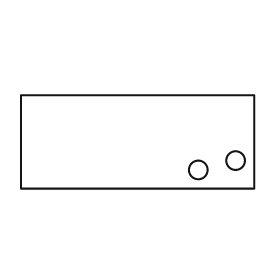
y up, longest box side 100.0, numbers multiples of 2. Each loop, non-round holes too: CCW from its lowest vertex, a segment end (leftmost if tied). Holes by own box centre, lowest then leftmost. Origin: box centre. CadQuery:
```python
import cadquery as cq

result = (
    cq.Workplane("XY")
    .moveTo(-50.0, -20.0)
    .lineTo(50.0, -20.0)
    .lineTo(50.0, 20.0)
    .lineTo(-50.0, 20.0)
    .close()
    .moveTo(26.0, -12.0)
    .circle(4.0)
    .moveTo(42.0, -8.0)
    .circle(4.0)
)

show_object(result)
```